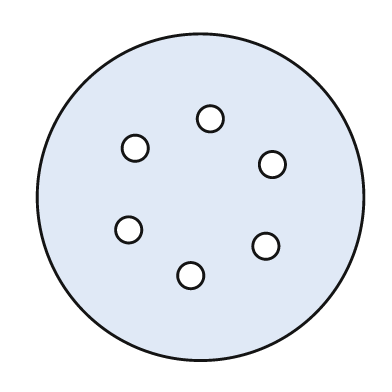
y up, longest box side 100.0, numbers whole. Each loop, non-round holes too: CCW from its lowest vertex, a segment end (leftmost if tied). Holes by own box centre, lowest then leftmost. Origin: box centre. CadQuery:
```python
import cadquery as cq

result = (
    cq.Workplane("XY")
    .moveTo(0.0, 0.0)
    .circle(50.0)
    .moveTo(-3.0, -24.0)
    .circle(4.0)
    .moveTo(20.0, -15.0)
    .circle(4.0)
    .moveTo(-22.0, -10.0)
    .circle(4.0)
    .moveTo(22.0, 10.0)
    .circle(4.0)
    .moveTo(-20.0, 15.0)
    .circle(4.0)
    .moveTo(3.0, 24.0)
    .circle(4.0)
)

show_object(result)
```